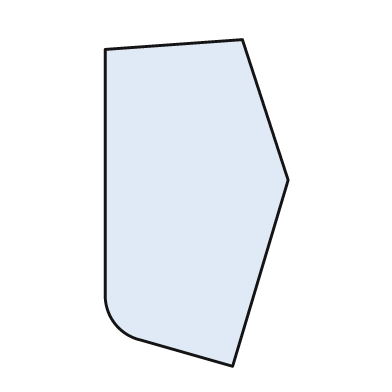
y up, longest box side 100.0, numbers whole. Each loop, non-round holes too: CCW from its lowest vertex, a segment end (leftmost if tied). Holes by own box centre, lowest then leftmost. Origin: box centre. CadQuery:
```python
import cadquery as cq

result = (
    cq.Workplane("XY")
    .moveTo(11.0, -50.0)
    .lineTo(28.0, 7.0)
    .lineTo(14.0, 50.0)
    .lineTo(-28.0, 47.0)
    .lineTo(-28.0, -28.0)
    .threePointArc((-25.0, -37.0), (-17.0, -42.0))
    .close()
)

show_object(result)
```